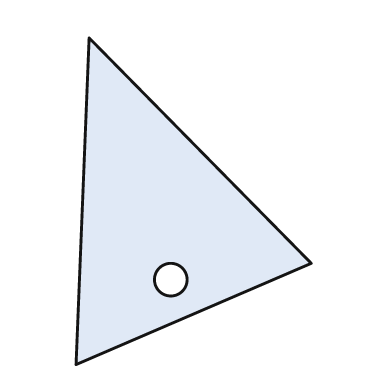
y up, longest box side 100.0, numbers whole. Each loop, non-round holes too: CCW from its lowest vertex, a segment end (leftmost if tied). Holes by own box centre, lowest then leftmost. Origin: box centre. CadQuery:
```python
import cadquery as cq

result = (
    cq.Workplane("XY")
    .moveTo(-36.0, -50.0)
    .lineTo(36.0, -19.0)
    .lineTo(-32.0, 50.0)
    .close()
    .moveTo(-7.0, -24.0)
    .circle(5.0)
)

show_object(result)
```